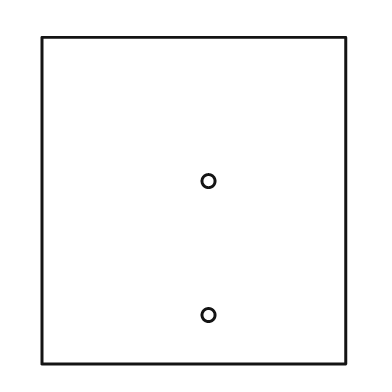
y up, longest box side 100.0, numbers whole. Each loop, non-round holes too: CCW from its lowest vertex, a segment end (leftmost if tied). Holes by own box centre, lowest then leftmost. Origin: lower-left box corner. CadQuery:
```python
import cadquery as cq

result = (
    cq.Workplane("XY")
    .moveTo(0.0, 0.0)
    .lineTo(93.0, 0.0)
    .lineTo(93.0, 100.0)
    .lineTo(0.0, 100.0)
    .close()
    .moveTo(51.0, 15.0)
    .circle(2.0)
    .moveTo(51.0, 56.0)
    .circle(2.0)
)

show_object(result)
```